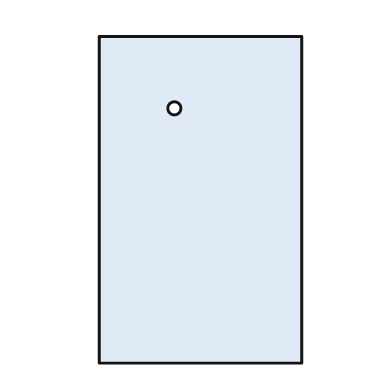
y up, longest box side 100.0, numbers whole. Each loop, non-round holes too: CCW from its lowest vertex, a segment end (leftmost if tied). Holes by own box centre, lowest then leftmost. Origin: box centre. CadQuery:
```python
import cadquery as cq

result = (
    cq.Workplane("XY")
    .moveTo(-31.0, -50.0)
    .lineTo(31.0, -50.0)
    .lineTo(31.0, 50.0)
    .lineTo(-31.0, 50.0)
    .close()
    .moveTo(-8.0, 28.0)
    .circle(2.0)
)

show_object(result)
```